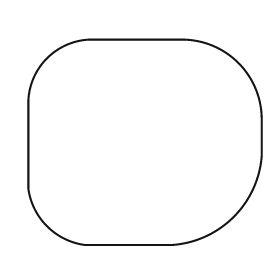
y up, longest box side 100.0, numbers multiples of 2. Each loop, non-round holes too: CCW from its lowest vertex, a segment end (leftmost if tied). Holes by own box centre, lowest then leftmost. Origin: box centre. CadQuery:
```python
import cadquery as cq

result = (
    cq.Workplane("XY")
    .moveTo(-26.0, -44.0)
    .lineTo(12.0, -44.0)
    .threePointArc((38.0, -32.0), (50.0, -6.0))
    .lineTo(50.0, 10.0)
    .threePointArc((40.0, 34.0), (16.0, 44.0))
    .lineTo(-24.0, 44.0)
    .threePointArc((-42.0, 36.0), (-50.0, 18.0))
    .lineTo(-50.0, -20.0)
    .threePointArc((-42.0, -36.0), (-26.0, -44.0))
    .close()
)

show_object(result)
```